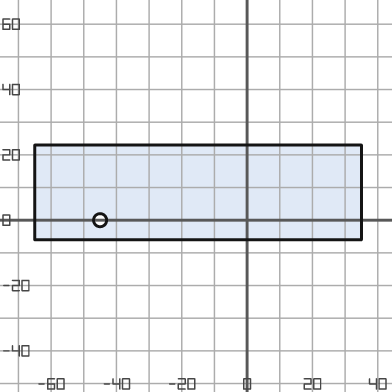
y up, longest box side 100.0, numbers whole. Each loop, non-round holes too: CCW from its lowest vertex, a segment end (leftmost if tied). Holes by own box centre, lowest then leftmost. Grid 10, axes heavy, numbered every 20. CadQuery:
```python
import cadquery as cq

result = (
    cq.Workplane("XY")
    .moveTo(-65.0, -6.0)
    .lineTo(35.0, -6.0)
    .lineTo(35.0, 23.0)
    .lineTo(-65.0, 23.0)
    .close()
    .moveTo(-45.0, 0.0)
    .circle(2.0)
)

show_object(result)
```